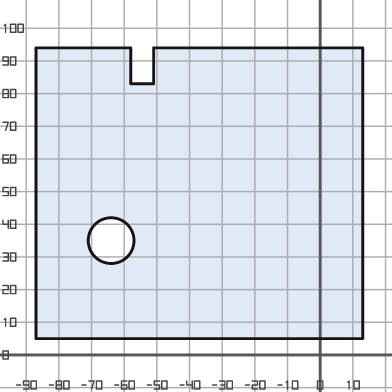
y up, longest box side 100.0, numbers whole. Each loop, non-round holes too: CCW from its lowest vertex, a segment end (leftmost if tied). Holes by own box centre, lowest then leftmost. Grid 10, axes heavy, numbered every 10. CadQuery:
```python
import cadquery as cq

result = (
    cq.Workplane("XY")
    .moveTo(-87.0, 5.0)
    .lineTo(13.0, 5.0)
    .lineTo(13.0, 94.0)
    .lineTo(-51.0, 94.0)
    .lineTo(-51.0, 83.0)
    .lineTo(-58.0, 83.0)
    .lineTo(-58.0, 94.0)
    .lineTo(-87.0, 94.0)
    .close()
    .moveTo(-64.0, 35.0)
    .circle(7.0)
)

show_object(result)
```